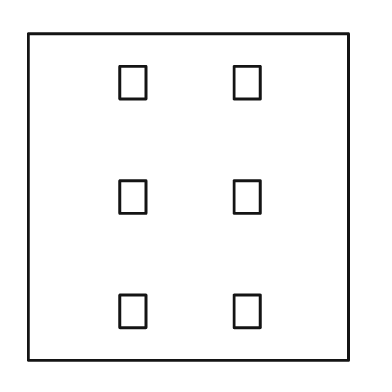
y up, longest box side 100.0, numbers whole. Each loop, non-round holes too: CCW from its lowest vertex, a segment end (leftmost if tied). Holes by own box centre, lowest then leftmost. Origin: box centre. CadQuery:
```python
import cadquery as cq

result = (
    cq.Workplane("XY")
    .moveTo(-49.0, -50.0)
    .lineTo(49.0, -50.0)
    .lineTo(49.0, 50.0)
    .lineTo(-49.0, 50.0)
    .close()
    .moveTo(-21.0, -40.0)
    .lineTo(-13.0, -40.0)
    .lineTo(-13.0, -30.0)
    .lineTo(-21.0, -30.0)
    .close()
    .moveTo(14.0, -40.0)
    .lineTo(22.0, -40.0)
    .lineTo(22.0, -30.0)
    .lineTo(14.0, -30.0)
    .close()
    .moveTo(-21.0, -5.0)
    .lineTo(-13.0, -5.0)
    .lineTo(-13.0, 5.0)
    .lineTo(-21.0, 5.0)
    .close()
    .moveTo(14.0, -5.0)
    .lineTo(22.0, -5.0)
    .lineTo(22.0, 5.0)
    .lineTo(14.0, 5.0)
    .close()
    .moveTo(-21.0, 30.0)
    .lineTo(-13.0, 30.0)
    .lineTo(-13.0, 40.0)
    .lineTo(-21.0, 40.0)
    .close()
    .moveTo(14.0, 30.0)
    .lineTo(22.0, 30.0)
    .lineTo(22.0, 40.0)
    .lineTo(14.0, 40.0)
    .close()
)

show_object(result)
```